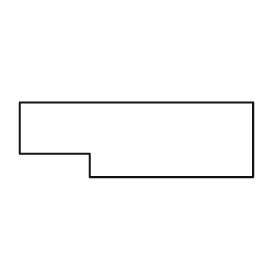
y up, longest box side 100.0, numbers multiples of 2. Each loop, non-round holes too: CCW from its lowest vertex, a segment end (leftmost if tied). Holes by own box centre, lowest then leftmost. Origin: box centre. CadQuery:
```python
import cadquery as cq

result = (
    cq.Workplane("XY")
    .moveTo(-20.0, -16.0)
    .lineTo(50.0, -16.0)
    .lineTo(50.0, 16.0)
    .lineTo(-50.0, 16.0)
    .lineTo(-50.0, -6.0)
    .lineTo(-20.0, -6.0)
    .close()
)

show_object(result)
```